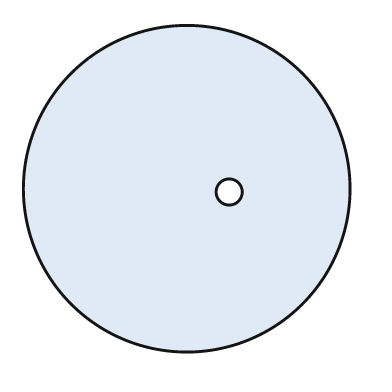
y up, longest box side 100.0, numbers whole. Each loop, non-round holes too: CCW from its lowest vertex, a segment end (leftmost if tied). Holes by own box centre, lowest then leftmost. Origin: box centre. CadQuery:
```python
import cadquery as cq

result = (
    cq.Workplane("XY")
    .moveTo(0.0, 0.0)
    .circle(50.0)
    .moveTo(13.0, -1.0)
    .circle(4.0)
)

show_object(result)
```